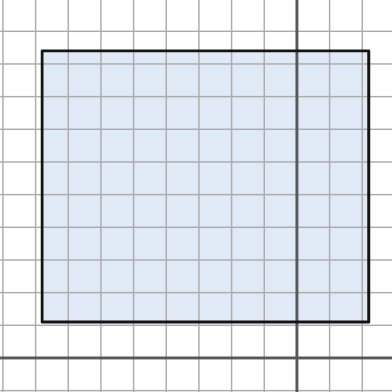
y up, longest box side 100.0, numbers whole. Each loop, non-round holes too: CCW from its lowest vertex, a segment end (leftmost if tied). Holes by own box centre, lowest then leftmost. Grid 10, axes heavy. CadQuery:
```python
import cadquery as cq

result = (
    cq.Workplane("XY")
    .moveTo(-78.0, 11.0)
    .lineTo(22.0, 11.0)
    .lineTo(22.0, 94.0)
    .lineTo(-78.0, 94.0)
    .close()
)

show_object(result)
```